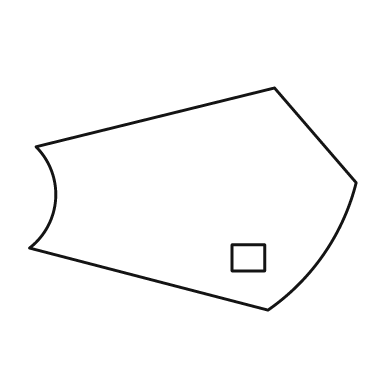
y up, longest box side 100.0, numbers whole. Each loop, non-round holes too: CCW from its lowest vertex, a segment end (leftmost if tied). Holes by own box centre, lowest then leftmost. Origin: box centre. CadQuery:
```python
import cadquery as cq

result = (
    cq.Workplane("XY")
    .moveTo(23.0, -34.0)
    .threePointArc((40.0, -17.0), (50.0, 5.0))
    .lineTo(25.0, 34.0)
    .lineTo(-48.0, 16.0)
    .threePointArc((-42.0, 0.0), (-50.0, -15.0))
    .close()
    .moveTo(12.0, -22.0)
    .lineTo(22.0, -22.0)
    .lineTo(22.0, -14.0)
    .lineTo(12.0, -14.0)
    .close()
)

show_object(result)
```